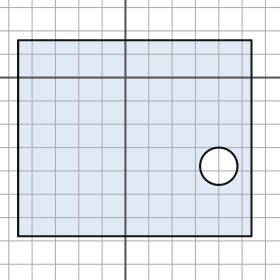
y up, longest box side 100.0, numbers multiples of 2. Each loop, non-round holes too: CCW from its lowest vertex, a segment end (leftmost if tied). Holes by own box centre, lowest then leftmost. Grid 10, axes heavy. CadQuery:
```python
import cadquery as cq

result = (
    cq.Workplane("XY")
    .moveTo(-46.0, -68.0)
    .lineTo(54.0, -68.0)
    .lineTo(54.0, 16.0)
    .lineTo(-46.0, 16.0)
    .close()
    .moveTo(40.0, -38.0)
    .circle(8.0)
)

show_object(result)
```